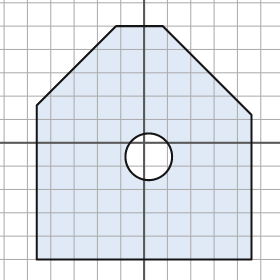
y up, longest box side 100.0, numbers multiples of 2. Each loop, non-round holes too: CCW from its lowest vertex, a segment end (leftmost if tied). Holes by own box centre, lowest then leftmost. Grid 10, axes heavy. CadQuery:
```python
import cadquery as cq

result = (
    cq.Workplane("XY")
    .moveTo(-46.0, -50.0)
    .lineTo(46.0, -50.0)
    .lineTo(46.0, 12.0)
    .lineTo(8.0, 50.0)
    .lineTo(-12.0, 50.0)
    .lineTo(-46.0, 16.0)
    .close()
    .moveTo(2.0, -6.0)
    .circle(10.0)
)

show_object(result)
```